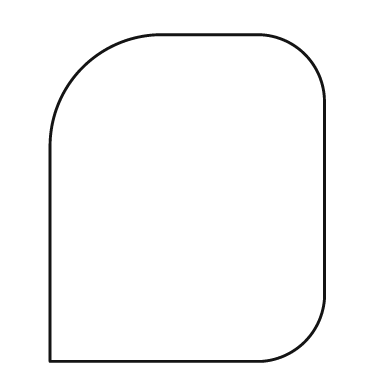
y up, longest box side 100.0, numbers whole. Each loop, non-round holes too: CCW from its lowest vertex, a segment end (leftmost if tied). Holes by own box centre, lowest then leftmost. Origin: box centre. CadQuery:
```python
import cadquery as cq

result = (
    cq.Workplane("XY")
    .moveTo(-42.0, -50.0)
    .lineTo(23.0, -50.0)
    .threePointArc((36.0, -44.0), (42.0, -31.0))
    .lineTo(42.0, 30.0)
    .threePointArc((36.0, 44.0), (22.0, 50.0))
    .lineTo(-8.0, 50.0)
    .threePointArc((-32.0, 40.0), (-42.0, 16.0))
    .close()
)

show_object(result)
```